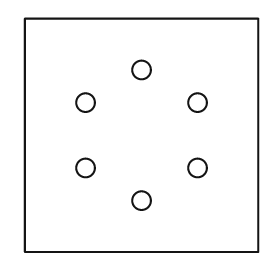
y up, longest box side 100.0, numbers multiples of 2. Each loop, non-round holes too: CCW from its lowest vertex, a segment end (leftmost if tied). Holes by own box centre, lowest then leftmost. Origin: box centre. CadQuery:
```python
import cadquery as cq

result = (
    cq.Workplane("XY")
    .moveTo(-50.0, -50.0)
    .lineTo(50.0, -50.0)
    .lineTo(50.0, 50.0)
    .lineTo(-50.0, 50.0)
    .close()
    .moveTo(0.0, -28.0)
    .circle(4.0)
    .moveTo(-24.0, -14.0)
    .circle(4.0)
    .moveTo(24.0, -14.0)
    .circle(4.0)
    .moveTo(-24.0, 14.0)
    .circle(4.0)
    .moveTo(24.0, 14.0)
    .circle(4.0)
    .moveTo(0.0, 28.0)
    .circle(4.0)
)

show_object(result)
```